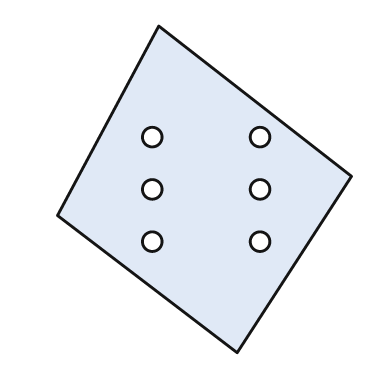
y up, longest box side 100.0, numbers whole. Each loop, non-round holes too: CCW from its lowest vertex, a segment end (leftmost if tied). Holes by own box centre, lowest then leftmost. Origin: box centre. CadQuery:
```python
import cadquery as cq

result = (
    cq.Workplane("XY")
    .moveTo(10.0, -50.0)
    .lineTo(45.0, 4.0)
    .lineTo(-14.0, 50.0)
    .lineTo(-45.0, -8.0)
    .close()
    .moveTo(-16.0, -16.0)
    .circle(3.0)
    .moveTo(17.0, -16.0)
    .circle(3.0)
    .moveTo(-16.0, 0.0)
    .circle(3.0)
    .moveTo(17.0, 0.0)
    .circle(3.0)
    .moveTo(-16.0, 16.0)
    .circle(3.0)
    .moveTo(17.0, 16.0)
    .circle(3.0)
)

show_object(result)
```